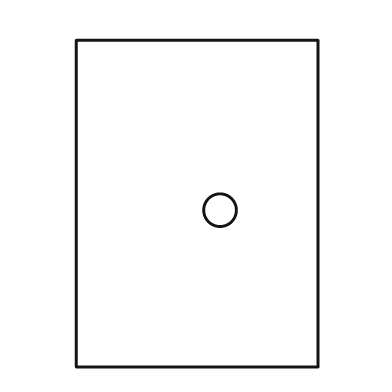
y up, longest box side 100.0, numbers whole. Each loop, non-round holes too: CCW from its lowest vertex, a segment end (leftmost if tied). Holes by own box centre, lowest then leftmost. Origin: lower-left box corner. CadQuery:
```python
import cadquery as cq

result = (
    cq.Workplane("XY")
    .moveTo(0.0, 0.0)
    .lineTo(74.0, 0.0)
    .lineTo(74.0, 100.0)
    .lineTo(0.0, 100.0)
    .close()
    .moveTo(44.0, 48.0)
    .circle(5.0)
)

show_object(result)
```